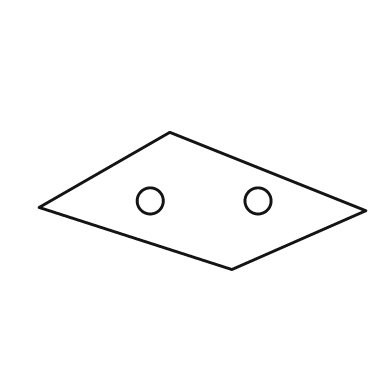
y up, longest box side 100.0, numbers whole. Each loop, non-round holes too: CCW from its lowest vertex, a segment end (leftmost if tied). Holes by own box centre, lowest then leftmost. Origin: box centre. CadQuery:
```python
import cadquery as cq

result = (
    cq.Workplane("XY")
    .moveTo(9.0, -21.0)
    .lineTo(50.0, -3.0)
    .lineTo(-10.0, 21.0)
    .lineTo(-50.0, -2.0)
    .close()
    .moveTo(-16.0, 0.0)
    .circle(4.0)
    .moveTo(17.0, 0.0)
    .circle(4.0)
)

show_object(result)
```